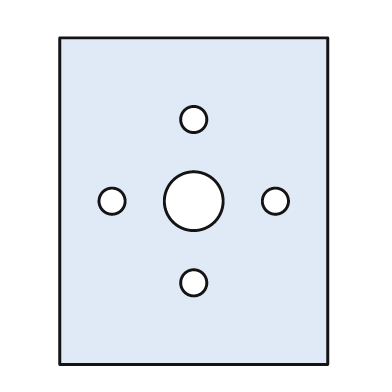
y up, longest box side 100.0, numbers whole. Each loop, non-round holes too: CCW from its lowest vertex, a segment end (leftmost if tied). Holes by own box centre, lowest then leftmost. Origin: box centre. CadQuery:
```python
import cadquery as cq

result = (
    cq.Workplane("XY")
    .moveTo(-41.0, -50.0)
    .lineTo(41.0, -50.0)
    .lineTo(41.0, 50.0)
    .lineTo(-41.0, 50.0)
    .close()
    .moveTo(0.0, -25.0)
    .circle(4.0)
    .moveTo(-25.0, 0.0)
    .circle(4.0)
    .moveTo(0.0, 0.0)
    .circle(9.0)
    .moveTo(25.0, 0.0)
    .circle(4.0)
    .moveTo(0.0, 25.0)
    .circle(4.0)
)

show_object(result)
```